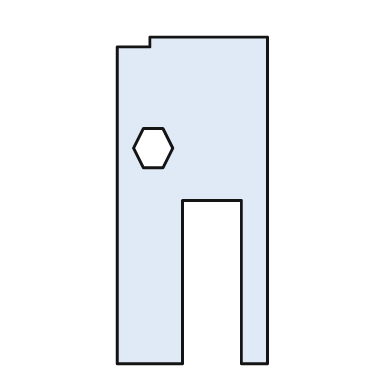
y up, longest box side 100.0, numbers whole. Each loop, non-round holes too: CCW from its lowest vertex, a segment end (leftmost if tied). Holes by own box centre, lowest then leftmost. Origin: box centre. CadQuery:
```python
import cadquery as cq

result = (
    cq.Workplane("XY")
    .moveTo(-23.0, -50.0)
    .lineTo(-3.0, -50.0)
    .lineTo(-3.0, 0.0)
    .lineTo(15.0, 0.0)
    .lineTo(15.0, -50.0)
    .lineTo(23.0, -50.0)
    .lineTo(23.0, 50.0)
    .lineTo(-13.0, 50.0)
    .lineTo(-13.0, 47.0)
    .lineTo(-23.0, 47.0)
    .close()
    .moveTo(-15.0, 10.0)
    .lineTo(-9.0, 10.0)
    .lineTo(-6.0, 16.0)
    .lineTo(-9.0, 22.0)
    .lineTo(-15.0, 22.0)
    .lineTo(-18.0, 16.0)
    .close()
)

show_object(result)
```